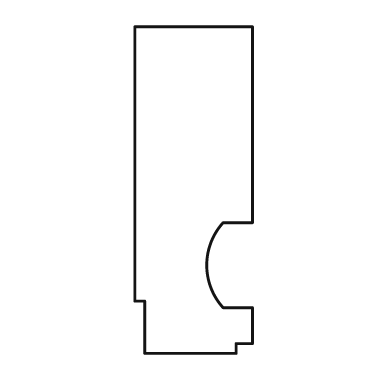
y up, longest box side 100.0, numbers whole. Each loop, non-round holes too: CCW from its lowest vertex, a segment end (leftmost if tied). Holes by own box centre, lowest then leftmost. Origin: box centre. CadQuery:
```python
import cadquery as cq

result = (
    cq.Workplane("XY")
    .moveTo(-15.0, -50.0)
    .lineTo(13.0, -50.0)
    .lineTo(13.0, -47.0)
    .lineTo(18.0, -47.0)
    .lineTo(18.0, -36.0)
    .lineTo(9.0, -36.0)
    .threePointArc((4.0, -23.0), (9.0, -10.0))
    .lineTo(18.0, -10.0)
    .lineTo(18.0, 50.0)
    .lineTo(-18.0, 50.0)
    .lineTo(-18.0, -34.0)
    .lineTo(-15.0, -34.0)
    .close()
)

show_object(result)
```